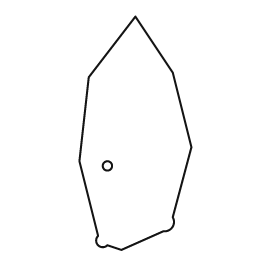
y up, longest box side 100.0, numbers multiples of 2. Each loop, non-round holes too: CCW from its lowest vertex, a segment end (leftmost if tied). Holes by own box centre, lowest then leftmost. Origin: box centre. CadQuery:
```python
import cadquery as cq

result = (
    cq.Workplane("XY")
    .moveTo(-6.0, -50.0)
    .lineTo(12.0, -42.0)
    .threePointArc((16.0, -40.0), (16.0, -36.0))
    .lineTo(24.0, -6.0)
    .lineTo(16.0, 26.0)
    .lineTo(0.0, 50.0)
    .lineTo(-20.0, 24.0)
    .lineTo(-24.0, -12.0)
    .lineTo(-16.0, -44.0)
    .threePointArc((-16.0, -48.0), (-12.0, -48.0))
    .close()
    .moveTo(-12.0, -14.0)
    .circle(2.0)
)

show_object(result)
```